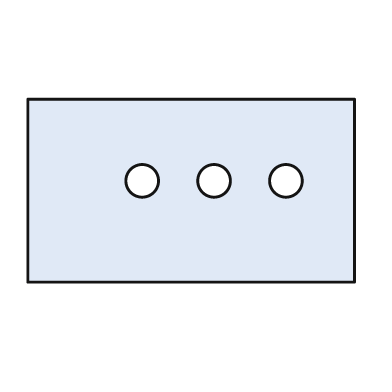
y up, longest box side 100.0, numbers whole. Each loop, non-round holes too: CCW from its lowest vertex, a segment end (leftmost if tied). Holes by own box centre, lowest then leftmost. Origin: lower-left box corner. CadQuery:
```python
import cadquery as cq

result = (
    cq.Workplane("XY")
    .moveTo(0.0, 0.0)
    .lineTo(100.0, 0.0)
    .lineTo(100.0, 56.0)
    .lineTo(0.0, 56.0)
    .close()
    .moveTo(35.0, 31.0)
    .circle(5.0)
    .moveTo(57.0, 31.0)
    .circle(5.0)
    .moveTo(79.0, 31.0)
    .circle(5.0)
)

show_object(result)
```